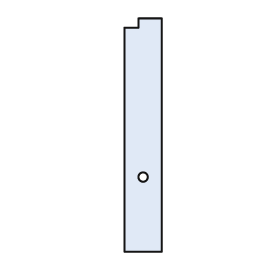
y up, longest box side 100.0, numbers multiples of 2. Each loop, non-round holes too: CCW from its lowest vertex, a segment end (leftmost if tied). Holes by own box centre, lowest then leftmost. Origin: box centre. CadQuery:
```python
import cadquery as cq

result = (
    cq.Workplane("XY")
    .moveTo(-8.0, -50.0)
    .lineTo(8.0, -50.0)
    .lineTo(8.0, 50.0)
    .lineTo(-2.0, 50.0)
    .lineTo(-2.0, 46.0)
    .lineTo(-8.0, 46.0)
    .close()
    .moveTo(0.0, -18.0)
    .circle(2.0)
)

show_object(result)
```